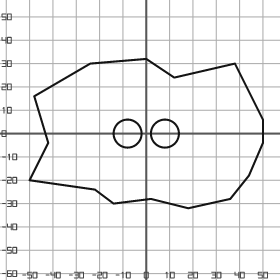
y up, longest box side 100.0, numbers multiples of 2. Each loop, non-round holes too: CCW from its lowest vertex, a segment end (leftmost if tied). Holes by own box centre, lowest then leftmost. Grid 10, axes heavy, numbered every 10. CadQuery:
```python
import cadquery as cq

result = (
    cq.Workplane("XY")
    .moveTo(18.0, -32.0)
    .lineTo(36.0, -28.0)
    .lineTo(44.0, -18.0)
    .lineTo(50.0, -4.0)
    .lineTo(50.0, 6.0)
    .lineTo(38.0, 30.0)
    .lineTo(12.0, 24.0)
    .lineTo(0.0, 32.0)
    .lineTo(-24.0, 30.0)
    .lineTo(-48.0, 16.0)
    .lineTo(-42.0, -4.0)
    .lineTo(-50.0, -20.0)
    .lineTo(-22.0, -24.0)
    .lineTo(-14.0, -30.0)
    .lineTo(2.0, -28.0)
    .close()
    .moveTo(-8.0, 0.0)
    .circle(6.0)
    .moveTo(8.0, 0.0)
    .circle(6.0)
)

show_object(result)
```